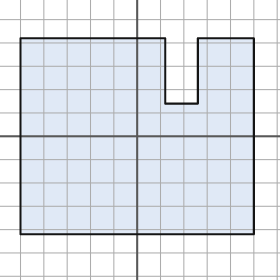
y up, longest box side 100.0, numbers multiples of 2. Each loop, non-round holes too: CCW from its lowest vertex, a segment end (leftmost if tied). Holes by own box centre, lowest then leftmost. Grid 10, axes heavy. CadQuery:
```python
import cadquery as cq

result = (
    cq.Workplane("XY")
    .moveTo(-50.0, -42.0)
    .lineTo(50.0, -42.0)
    .lineTo(50.0, 42.0)
    .lineTo(26.0, 42.0)
    .lineTo(26.0, 14.0)
    .lineTo(12.0, 14.0)
    .lineTo(12.0, 42.0)
    .lineTo(-50.0, 42.0)
    .close()
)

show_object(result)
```